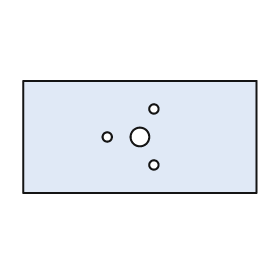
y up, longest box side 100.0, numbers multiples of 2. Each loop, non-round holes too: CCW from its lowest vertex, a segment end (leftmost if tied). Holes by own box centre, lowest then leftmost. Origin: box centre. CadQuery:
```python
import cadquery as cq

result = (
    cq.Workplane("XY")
    .moveTo(-50.0, -24.0)
    .lineTo(50.0, -24.0)
    .lineTo(50.0, 24.0)
    .lineTo(-50.0, 24.0)
    .close()
    .moveTo(6.0, -12.0)
    .circle(2.0)
    .moveTo(-14.0, 0.0)
    .circle(2.0)
    .moveTo(0.0, 0.0)
    .circle(4.0)
    .moveTo(6.0, 12.0)
    .circle(2.0)
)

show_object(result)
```